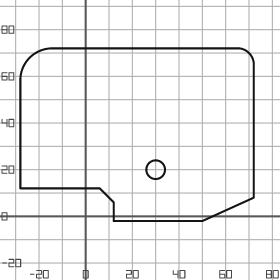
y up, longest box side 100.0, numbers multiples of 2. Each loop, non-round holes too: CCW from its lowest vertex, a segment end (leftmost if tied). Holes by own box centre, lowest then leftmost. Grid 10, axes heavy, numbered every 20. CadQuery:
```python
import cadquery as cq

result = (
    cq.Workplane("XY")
    .moveTo(12.0, -2.0)
    .lineTo(50.0, -2.0)
    .lineTo(72.0, 8.0)
    .lineTo(72.0, 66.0)
    .threePointArc((70.0, 70.0), (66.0, 72.0))
    .lineTo(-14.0, 72.0)
    .threePointArc((-24.0, 68.0), (-28.0, 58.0))
    .lineTo(-28.0, 12.0)
    .lineTo(6.0, 12.0)
    .lineTo(12.0, 6.0)
    .close()
    .moveTo(30.0, 20.0)
    .circle(4.0)
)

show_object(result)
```